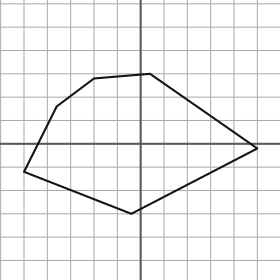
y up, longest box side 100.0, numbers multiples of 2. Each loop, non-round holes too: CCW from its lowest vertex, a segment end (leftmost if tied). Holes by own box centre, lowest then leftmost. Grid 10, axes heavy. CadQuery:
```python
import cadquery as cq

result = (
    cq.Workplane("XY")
    .moveTo(-4.0, -30.0)
    .lineTo(50.0, -2.0)
    .lineTo(4.0, 30.0)
    .lineTo(-20.0, 28.0)
    .lineTo(-36.0, 16.0)
    .lineTo(-50.0, -12.0)
    .close()
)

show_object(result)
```